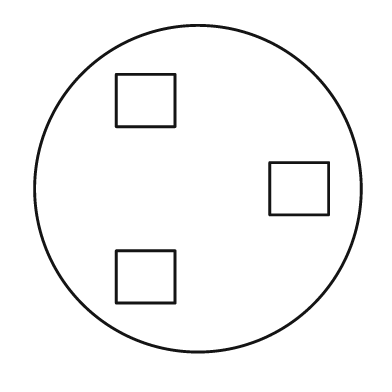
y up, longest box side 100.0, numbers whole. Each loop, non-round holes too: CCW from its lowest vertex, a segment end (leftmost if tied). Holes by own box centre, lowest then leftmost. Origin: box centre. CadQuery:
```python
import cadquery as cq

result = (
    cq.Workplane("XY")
    .moveTo(0.0, 0.0)
    .circle(50.0)
    .moveTo(-25.0, -35.0)
    .lineTo(-7.0, -35.0)
    .lineTo(-7.0, -19.0)
    .lineTo(-25.0, -19.0)
    .close()
    .moveTo(22.0, -8.0)
    .lineTo(40.0, -8.0)
    .lineTo(40.0, 8.0)
    .lineTo(22.0, 8.0)
    .close()
    .moveTo(-25.0, 19.0)
    .lineTo(-7.0, 19.0)
    .lineTo(-7.0, 35.0)
    .lineTo(-25.0, 35.0)
    .close()
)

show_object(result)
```